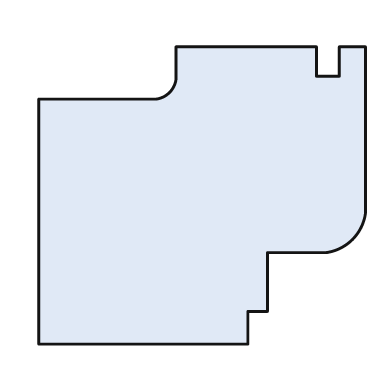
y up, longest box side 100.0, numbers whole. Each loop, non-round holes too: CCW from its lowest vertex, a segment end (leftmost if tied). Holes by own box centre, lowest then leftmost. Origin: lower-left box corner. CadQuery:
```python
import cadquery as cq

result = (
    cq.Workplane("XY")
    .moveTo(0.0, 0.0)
    .lineTo(64.0, 0.0)
    .lineTo(64.0, 10.0)
    .lineTo(70.0, 10.0)
    .lineTo(70.0, 28.0)
    .lineTo(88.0, 28.0)
    .threePointArc((96.0, 32.0), (100.0, 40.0))
    .lineTo(100.0, 91.0)
    .lineTo(92.0, 91.0)
    .lineTo(92.0, 82.0)
    .lineTo(85.0, 82.0)
    .lineTo(85.0, 91.0)
    .lineTo(42.0, 91.0)
    .lineTo(42.0, 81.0)
    .threePointArc((40.0, 77.0), (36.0, 75.0))
    .lineTo(0.0, 75.0)
    .close()
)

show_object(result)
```